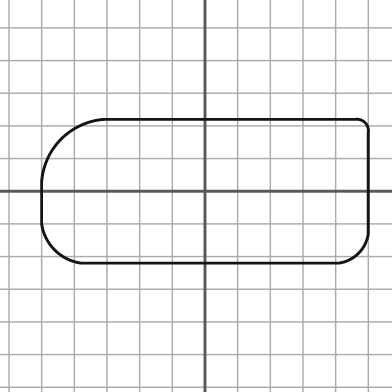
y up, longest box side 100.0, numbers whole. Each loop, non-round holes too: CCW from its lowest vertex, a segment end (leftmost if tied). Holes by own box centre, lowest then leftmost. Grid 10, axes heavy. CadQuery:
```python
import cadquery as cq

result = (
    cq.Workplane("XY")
    .moveTo(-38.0, -22.0)
    .lineTo(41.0, -22.0)
    .threePointArc((47.0, -19.0), (50.0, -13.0))
    .lineTo(50.0, 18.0)
    .threePointArc((49.0, 21.0), (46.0, 22.0))
    .lineTo(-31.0, 22.0)
    .threePointArc((-44.0, 16.0), (-50.0, 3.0))
    .lineTo(-50.0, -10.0)
    .threePointArc((-46.0, -18.0), (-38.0, -22.0))
    .close()
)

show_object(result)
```